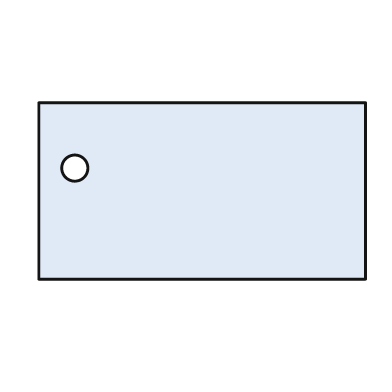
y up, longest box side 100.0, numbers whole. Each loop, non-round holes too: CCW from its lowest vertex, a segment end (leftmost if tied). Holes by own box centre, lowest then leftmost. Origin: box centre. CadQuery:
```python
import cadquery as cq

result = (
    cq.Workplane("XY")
    .moveTo(-50.0, -27.0)
    .lineTo(50.0, -27.0)
    .lineTo(50.0, 27.0)
    .lineTo(-50.0, 27.0)
    .close()
    .moveTo(-39.0, 7.0)
    .circle(4.0)
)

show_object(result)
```